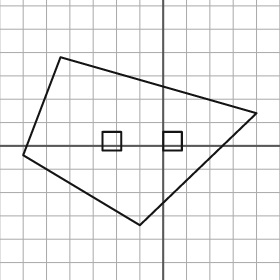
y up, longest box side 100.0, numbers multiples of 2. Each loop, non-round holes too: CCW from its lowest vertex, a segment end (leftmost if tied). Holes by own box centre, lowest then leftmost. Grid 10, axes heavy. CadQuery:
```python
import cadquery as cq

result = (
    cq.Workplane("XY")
    .moveTo(-10.0, -34.0)
    .lineTo(40.0, 14.0)
    .lineTo(-44.0, 38.0)
    .lineTo(-60.0, -4.0)
    .close()
    .moveTo(-26.0, -2.0)
    .lineTo(-18.0, -2.0)
    .lineTo(-18.0, 6.0)
    .lineTo(-26.0, 6.0)
    .close()
    .moveTo(0.0, -2.0)
    .lineTo(8.0, -2.0)
    .lineTo(8.0, 6.0)
    .lineTo(0.0, 6.0)
    .close()
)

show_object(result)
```